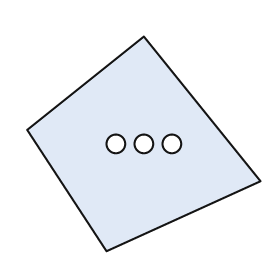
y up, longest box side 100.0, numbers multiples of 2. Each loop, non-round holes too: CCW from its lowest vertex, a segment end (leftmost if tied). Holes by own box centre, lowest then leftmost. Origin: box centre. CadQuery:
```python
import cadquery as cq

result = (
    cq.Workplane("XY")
    .moveTo(-16.0, -46.0)
    .lineTo(50.0, -16.0)
    .lineTo(0.0, 46.0)
    .lineTo(-50.0, 6.0)
    .close()
    .moveTo(-12.0, 0.0)
    .circle(4.0)
    .moveTo(0.0, 0.0)
    .circle(4.0)
    .moveTo(12.0, 0.0)
    .circle(4.0)
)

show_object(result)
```